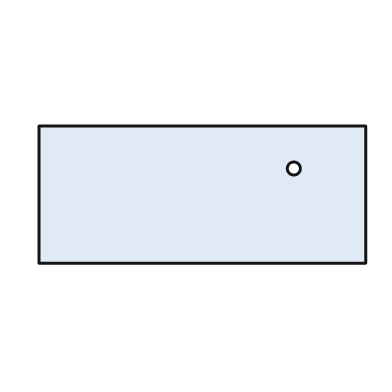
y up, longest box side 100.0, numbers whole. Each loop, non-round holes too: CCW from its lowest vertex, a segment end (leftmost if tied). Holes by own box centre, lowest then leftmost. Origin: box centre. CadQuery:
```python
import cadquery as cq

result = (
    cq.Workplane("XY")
    .moveTo(-50.0, -21.0)
    .lineTo(50.0, -21.0)
    .lineTo(50.0, 21.0)
    .lineTo(-50.0, 21.0)
    .close()
    .moveTo(28.0, 8.0)
    .circle(2.0)
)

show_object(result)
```